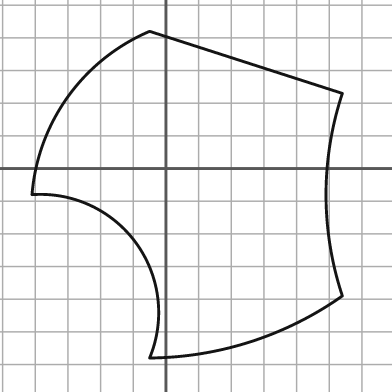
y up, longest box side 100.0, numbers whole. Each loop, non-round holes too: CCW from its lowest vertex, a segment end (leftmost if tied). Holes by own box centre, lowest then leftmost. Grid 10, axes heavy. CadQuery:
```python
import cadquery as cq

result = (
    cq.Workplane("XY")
    .moveTo(-5.0, -58.0)
    .threePointArc((26.0, -53.0), (54.0, -39.0))
    .threePointArc((49.0, -8.0), (54.0, 23.0))
    .lineTo(-5.0, 42.0)
    .threePointArc((-30.0, 22.0), (-41.0, -8.0))
    .threePointArc((-9.0, -23.0), (-5.0, -58.0))
    .close()
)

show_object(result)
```